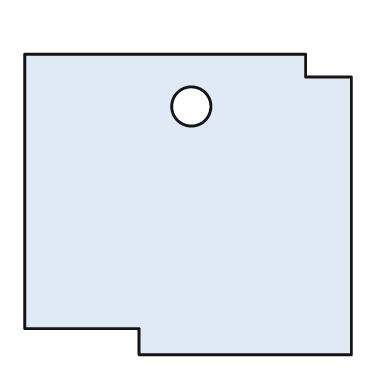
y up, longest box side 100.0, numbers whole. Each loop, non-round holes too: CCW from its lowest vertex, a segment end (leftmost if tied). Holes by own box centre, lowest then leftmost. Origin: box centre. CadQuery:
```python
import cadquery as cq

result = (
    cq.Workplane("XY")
    .moveTo(-15.0, -46.0)
    .lineTo(50.0, -46.0)
    .lineTo(50.0, 39.0)
    .lineTo(36.0, 39.0)
    .lineTo(36.0, 46.0)
    .lineTo(-50.0, 46.0)
    .lineTo(-50.0, -38.0)
    .lineTo(-15.0, -38.0)
    .close()
    .moveTo(1.0, 30.0)
    .circle(6.0)
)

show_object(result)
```